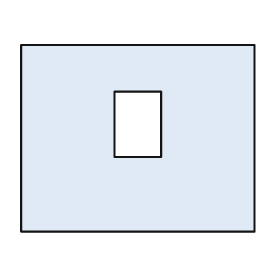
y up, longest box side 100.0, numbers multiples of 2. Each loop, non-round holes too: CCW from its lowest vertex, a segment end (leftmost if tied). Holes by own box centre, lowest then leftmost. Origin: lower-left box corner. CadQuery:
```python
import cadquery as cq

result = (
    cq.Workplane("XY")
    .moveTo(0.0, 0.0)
    .lineTo(100.0, 0.0)
    .lineTo(100.0, 80.0)
    .lineTo(0.0, 80.0)
    .close()
    .moveTo(40.0, 32.0)
    .lineTo(60.0, 32.0)
    .lineTo(60.0, 60.0)
    .lineTo(40.0, 60.0)
    .close()
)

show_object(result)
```